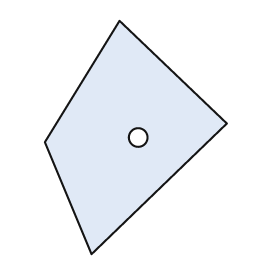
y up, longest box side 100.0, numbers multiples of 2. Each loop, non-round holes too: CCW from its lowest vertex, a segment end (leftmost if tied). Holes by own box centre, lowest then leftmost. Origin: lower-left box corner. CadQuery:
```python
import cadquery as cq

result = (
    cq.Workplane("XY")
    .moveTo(20.0, 0.0)
    .lineTo(78.0, 56.0)
    .lineTo(32.0, 100.0)
    .lineTo(0.0, 48.0)
    .close()
    .moveTo(40.0, 50.0)
    .circle(4.0)
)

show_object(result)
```